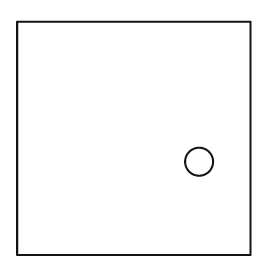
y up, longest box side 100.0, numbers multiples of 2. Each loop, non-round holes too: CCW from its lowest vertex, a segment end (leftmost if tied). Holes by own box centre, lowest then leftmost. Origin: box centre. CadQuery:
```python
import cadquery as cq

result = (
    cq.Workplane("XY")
    .moveTo(-50.0, -50.0)
    .lineTo(50.0, -50.0)
    .lineTo(50.0, 50.0)
    .lineTo(-50.0, 50.0)
    .close()
    .moveTo(28.0, -10.0)
    .circle(6.0)
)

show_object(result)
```